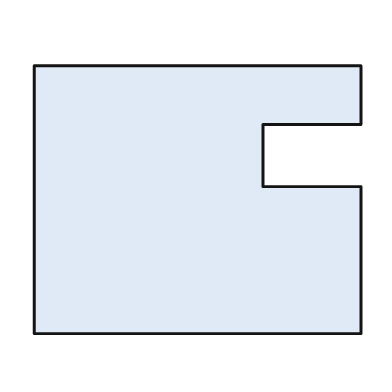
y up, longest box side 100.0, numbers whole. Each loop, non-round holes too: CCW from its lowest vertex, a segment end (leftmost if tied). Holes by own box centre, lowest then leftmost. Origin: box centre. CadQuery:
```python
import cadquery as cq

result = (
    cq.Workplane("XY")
    .moveTo(-50.0, -41.0)
    .lineTo(50.0, -41.0)
    .lineTo(50.0, 4.0)
    .lineTo(20.0, 4.0)
    .lineTo(20.0, 23.0)
    .lineTo(50.0, 23.0)
    .lineTo(50.0, 41.0)
    .lineTo(-50.0, 41.0)
    .close()
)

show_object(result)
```